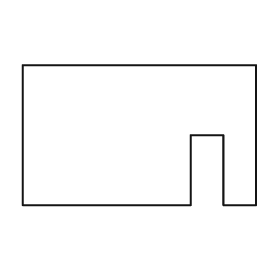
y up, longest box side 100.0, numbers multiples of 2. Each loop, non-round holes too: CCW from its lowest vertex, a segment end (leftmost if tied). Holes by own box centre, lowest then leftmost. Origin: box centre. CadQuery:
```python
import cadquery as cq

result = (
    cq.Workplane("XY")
    .moveTo(-50.0, -30.0)
    .lineTo(22.0, -30.0)
    .lineTo(22.0, 0.0)
    .lineTo(36.0, 0.0)
    .lineTo(36.0, -30.0)
    .lineTo(50.0, -30.0)
    .lineTo(50.0, 30.0)
    .lineTo(-50.0, 30.0)
    .close()
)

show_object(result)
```